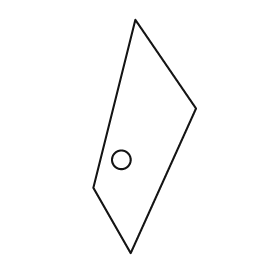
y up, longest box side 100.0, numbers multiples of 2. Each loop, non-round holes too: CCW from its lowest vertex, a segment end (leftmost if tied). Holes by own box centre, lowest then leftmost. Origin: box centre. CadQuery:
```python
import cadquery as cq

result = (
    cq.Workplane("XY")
    .moveTo(-6.0, -50.0)
    .lineTo(22.0, 12.0)
    .lineTo(-4.0, 50.0)
    .lineTo(-22.0, -22.0)
    .close()
    .moveTo(-10.0, -10.0)
    .circle(4.0)
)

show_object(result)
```